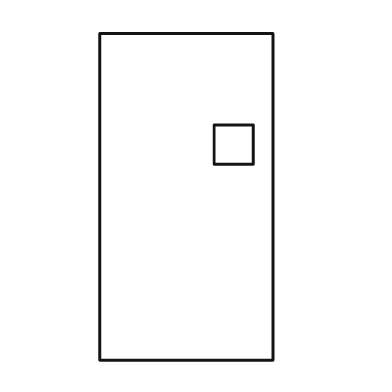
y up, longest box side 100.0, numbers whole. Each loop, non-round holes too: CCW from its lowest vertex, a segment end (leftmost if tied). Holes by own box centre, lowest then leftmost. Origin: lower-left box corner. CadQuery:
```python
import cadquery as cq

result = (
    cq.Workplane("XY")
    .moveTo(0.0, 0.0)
    .lineTo(53.0, 0.0)
    .lineTo(53.0, 100.0)
    .lineTo(0.0, 100.0)
    .close()
    .moveTo(35.0, 60.0)
    .lineTo(47.0, 60.0)
    .lineTo(47.0, 72.0)
    .lineTo(35.0, 72.0)
    .close()
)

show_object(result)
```